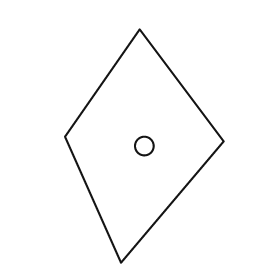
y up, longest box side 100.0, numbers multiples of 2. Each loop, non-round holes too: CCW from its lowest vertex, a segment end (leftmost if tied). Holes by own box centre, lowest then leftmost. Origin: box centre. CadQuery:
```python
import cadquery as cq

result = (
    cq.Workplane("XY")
    .moveTo(-10.0, -50.0)
    .lineTo(34.0, 2.0)
    .lineTo(-2.0, 50.0)
    .lineTo(-34.0, 4.0)
    .close()
    .moveTo(0.0, 0.0)
    .circle(4.0)
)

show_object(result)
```